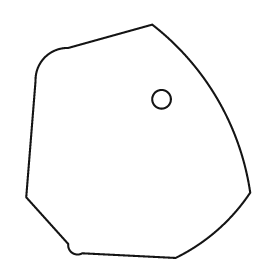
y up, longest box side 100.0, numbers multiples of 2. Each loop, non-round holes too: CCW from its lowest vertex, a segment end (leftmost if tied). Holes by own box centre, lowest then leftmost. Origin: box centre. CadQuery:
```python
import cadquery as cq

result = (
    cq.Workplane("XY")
    .moveTo(16.0, -50.0)
    .threePointArc((34.0, -38.0), (48.0, -22.0))
    .threePointArc((34.0, 18.0), (6.0, 50.0))
    .lineTo(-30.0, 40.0)
    .threePointArc((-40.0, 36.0), (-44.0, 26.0))
    .lineTo(-48.0, -24.0)
    .lineTo(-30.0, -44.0)
    .threePointArc((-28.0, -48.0), (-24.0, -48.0))
    .close()
    .moveTo(10.0, 18.0)
    .circle(4.0)
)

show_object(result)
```